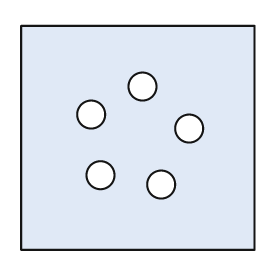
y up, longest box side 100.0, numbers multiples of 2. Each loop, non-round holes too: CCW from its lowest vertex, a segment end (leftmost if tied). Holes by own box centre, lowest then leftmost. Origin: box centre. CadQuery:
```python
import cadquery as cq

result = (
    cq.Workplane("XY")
    .moveTo(-50.0, -48.0)
    .lineTo(50.0, -48.0)
    .lineTo(50.0, 48.0)
    .lineTo(-50.0, 48.0)
    .close()
    .moveTo(10.0, -20.0)
    .circle(6.0)
    .moveTo(-16.0, -16.0)
    .circle(6.0)
    .moveTo(22.0, 4.0)
    .circle(6.0)
    .moveTo(-20.0, 10.0)
    .circle(6.0)
    .moveTo(2.0, 22.0)
    .circle(6.0)
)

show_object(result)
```